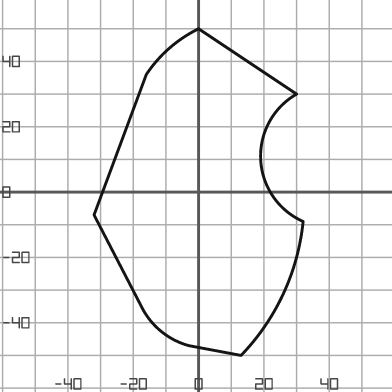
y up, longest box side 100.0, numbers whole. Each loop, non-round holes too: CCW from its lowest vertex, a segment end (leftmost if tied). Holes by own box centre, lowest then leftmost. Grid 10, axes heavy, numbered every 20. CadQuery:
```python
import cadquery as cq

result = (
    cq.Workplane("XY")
    .moveTo(13.0, -50.0)
    .threePointArc((26.0, -31.0), (32.0, -9.0))
    .threePointArc((19.0, 10.0), (30.0, 30.0))
    .lineTo(0.0, 50.0)
    .threePointArc((-9.0, 44.0), (-16.0, 36.0))
    .lineTo(-32.0, -7.0)
    .lineTo(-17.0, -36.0)
    .threePointArc((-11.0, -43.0), (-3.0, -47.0))
    .close()
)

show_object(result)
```